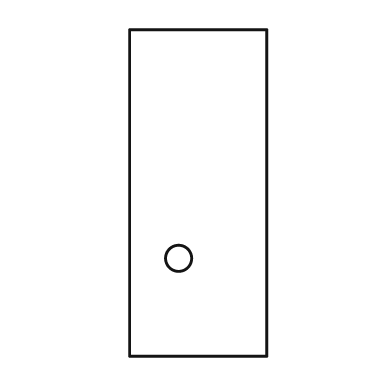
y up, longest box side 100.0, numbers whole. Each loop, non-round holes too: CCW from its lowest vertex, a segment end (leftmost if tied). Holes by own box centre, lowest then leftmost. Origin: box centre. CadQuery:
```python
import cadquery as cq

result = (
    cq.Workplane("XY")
    .moveTo(-21.0, -50.0)
    .lineTo(21.0, -50.0)
    .lineTo(21.0, 50.0)
    .lineTo(-21.0, 50.0)
    .close()
    .moveTo(-6.0, -20.0)
    .circle(4.0)
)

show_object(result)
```